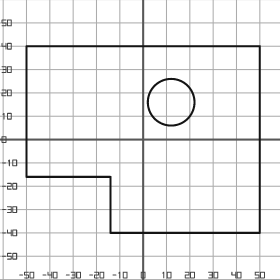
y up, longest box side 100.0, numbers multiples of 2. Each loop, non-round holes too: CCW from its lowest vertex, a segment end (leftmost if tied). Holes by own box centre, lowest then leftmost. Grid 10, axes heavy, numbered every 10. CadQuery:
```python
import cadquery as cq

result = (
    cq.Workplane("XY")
    .moveTo(-14.0, -40.0)
    .lineTo(50.0, -40.0)
    .lineTo(50.0, 40.0)
    .lineTo(-50.0, 40.0)
    .lineTo(-50.0, -16.0)
    .lineTo(-14.0, -16.0)
    .close()
    .moveTo(12.0, 16.0)
    .circle(10.0)
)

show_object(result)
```